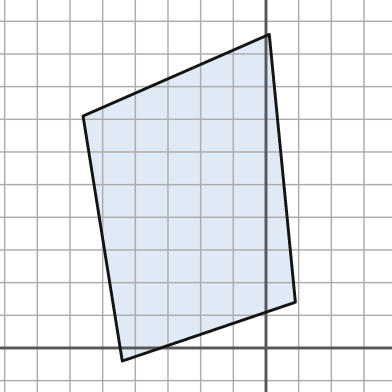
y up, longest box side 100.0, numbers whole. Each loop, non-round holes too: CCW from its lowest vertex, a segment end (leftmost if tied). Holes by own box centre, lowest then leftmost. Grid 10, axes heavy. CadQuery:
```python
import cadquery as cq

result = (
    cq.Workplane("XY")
    .moveTo(-44.0, -4.0)
    .lineTo(9.0, 14.0)
    .lineTo(1.0, 96.0)
    .lineTo(-56.0, 71.0)
    .close()
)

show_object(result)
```